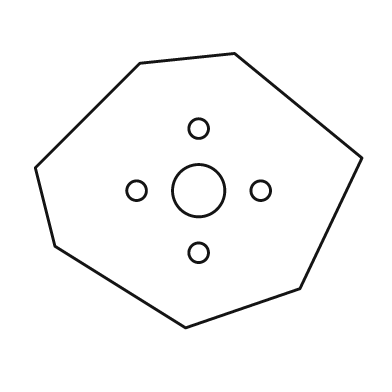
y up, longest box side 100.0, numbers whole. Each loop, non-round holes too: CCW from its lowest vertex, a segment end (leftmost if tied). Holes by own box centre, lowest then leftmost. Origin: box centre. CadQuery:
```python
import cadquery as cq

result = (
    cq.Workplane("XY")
    .moveTo(-4.0, -42.0)
    .lineTo(31.0, -30.0)
    .lineTo(50.0, 10.0)
    .lineTo(11.0, 42.0)
    .lineTo(-18.0, 39.0)
    .lineTo(-50.0, 7.0)
    .lineTo(-44.0, -17.0)
    .close()
    .moveTo(0.0, -19.0)
    .circle(3.0)
    .moveTo(-19.0, 0.0)
    .circle(3.0)
    .moveTo(0.0, 0.0)
    .circle(8.0)
    .moveTo(19.0, 0.0)
    .circle(3.0)
    .moveTo(0.0, 19.0)
    .circle(3.0)
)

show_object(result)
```